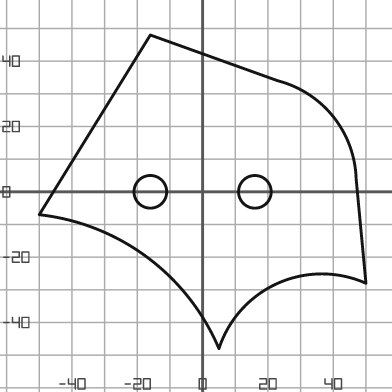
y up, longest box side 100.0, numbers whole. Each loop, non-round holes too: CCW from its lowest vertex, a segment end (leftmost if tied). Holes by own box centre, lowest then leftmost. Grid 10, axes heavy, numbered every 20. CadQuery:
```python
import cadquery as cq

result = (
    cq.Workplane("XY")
    .moveTo(5.0, -48.0)
    .threePointArc((23.0, -28.0), (50.0, -28.0))
    .lineTo(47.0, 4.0)
    .threePointArc((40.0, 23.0), (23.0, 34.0))
    .lineTo(-16.0, 48.0)
    .lineTo(-50.0, -7.0)
    .threePointArc((-17.0, -20.0), (5.0, -48.0))
    .close()
    .moveTo(-16.0, 0.0)
    .circle(5.0)
    .moveTo(16.0, 0.0)
    .circle(5.0)
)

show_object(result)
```